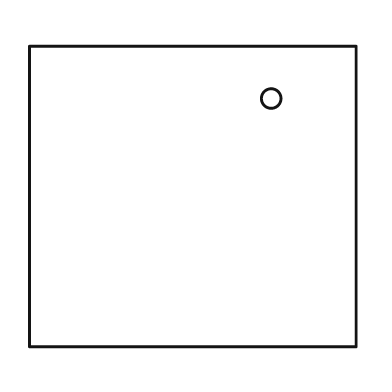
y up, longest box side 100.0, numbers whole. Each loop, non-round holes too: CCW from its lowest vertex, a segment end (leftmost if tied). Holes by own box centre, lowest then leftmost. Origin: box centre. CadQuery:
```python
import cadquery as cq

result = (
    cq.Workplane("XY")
    .moveTo(-50.0, -46.0)
    .lineTo(50.0, -46.0)
    .lineTo(50.0, 46.0)
    .lineTo(-50.0, 46.0)
    .close()
    .moveTo(24.0, 30.0)
    .circle(3.0)
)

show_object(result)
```